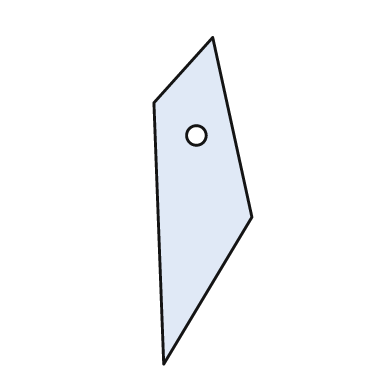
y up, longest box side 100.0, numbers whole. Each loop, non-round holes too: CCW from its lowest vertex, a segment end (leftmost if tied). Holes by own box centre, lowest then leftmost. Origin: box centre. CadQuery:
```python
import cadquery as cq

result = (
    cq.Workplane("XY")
    .moveTo(-12.0, -50.0)
    .lineTo(15.0, -5.0)
    .lineTo(3.0, 50.0)
    .lineTo(-15.0, 30.0)
    .close()
    .moveTo(-2.0, 20.0)
    .circle(3.0)
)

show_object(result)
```